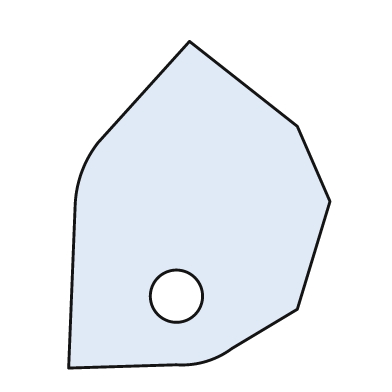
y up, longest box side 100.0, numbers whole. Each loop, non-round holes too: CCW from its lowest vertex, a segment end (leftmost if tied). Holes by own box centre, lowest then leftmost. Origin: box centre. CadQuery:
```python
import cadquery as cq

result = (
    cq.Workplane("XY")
    .moveTo(-40.0, -50.0)
    .lineTo(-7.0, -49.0)
    .threePointArc((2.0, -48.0), (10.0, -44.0))
    .lineTo(30.0, -32.0)
    .lineTo(40.0, 1.0)
    .lineTo(30.0, 24.0)
    .lineTo(-3.0, 50.0)
    .lineTo(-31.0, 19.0)
    .threePointArc((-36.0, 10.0), (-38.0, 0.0))
    .close()
    .moveTo(-7.0, -28.0)
    .circle(8.0)
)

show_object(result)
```